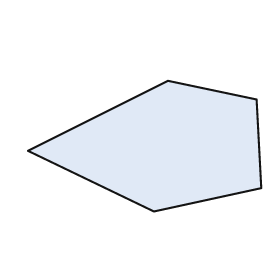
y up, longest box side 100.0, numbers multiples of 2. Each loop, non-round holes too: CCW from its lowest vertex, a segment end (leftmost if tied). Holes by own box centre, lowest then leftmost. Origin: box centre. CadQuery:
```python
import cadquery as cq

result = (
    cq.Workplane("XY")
    .moveTo(4.0, -28.0)
    .lineTo(50.0, -18.0)
    .lineTo(48.0, 20.0)
    .lineTo(10.0, 28.0)
    .lineTo(-50.0, -2.0)
    .close()
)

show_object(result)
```